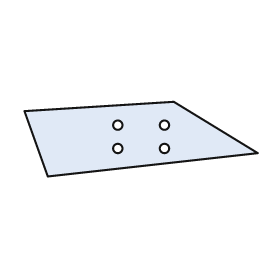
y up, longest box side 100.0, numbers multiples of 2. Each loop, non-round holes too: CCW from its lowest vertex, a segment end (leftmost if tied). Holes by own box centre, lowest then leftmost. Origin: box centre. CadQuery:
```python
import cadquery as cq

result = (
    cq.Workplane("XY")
    .moveTo(-40.0, -16.0)
    .lineTo(50.0, -6.0)
    .lineTo(14.0, 16.0)
    .lineTo(-50.0, 12.0)
    .close()
    .moveTo(-10.0, -4.0)
    .circle(2.0)
    .moveTo(10.0, -4.0)
    .circle(2.0)
    .moveTo(-10.0, 6.0)
    .circle(2.0)
    .moveTo(10.0, 6.0)
    .circle(2.0)
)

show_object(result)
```